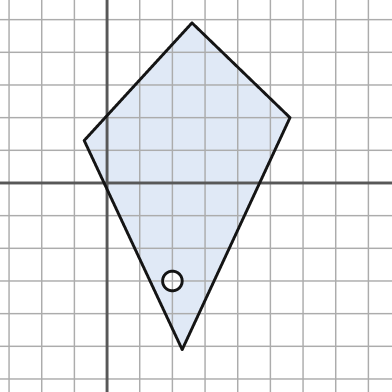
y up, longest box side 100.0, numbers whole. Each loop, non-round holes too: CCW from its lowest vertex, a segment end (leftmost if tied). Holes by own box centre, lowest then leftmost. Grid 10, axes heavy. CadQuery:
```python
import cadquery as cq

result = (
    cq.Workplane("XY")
    .moveTo(23.0, -51.0)
    .lineTo(56.0, 20.0)
    .lineTo(26.0, 49.0)
    .lineTo(-7.0, 13.0)
    .close()
    .moveTo(20.0, -30.0)
    .circle(3.0)
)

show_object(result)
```